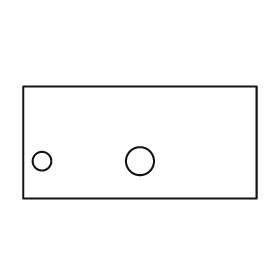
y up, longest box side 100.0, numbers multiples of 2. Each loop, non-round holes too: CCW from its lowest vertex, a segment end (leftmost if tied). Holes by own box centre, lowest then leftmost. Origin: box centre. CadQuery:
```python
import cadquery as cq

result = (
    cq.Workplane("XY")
    .moveTo(-50.0, -24.0)
    .lineTo(50.0, -24.0)
    .lineTo(50.0, 24.0)
    .lineTo(-50.0, 24.0)
    .close()
    .moveTo(-42.0, -8.0)
    .circle(4.0)
    .moveTo(0.0, -8.0)
    .circle(6.0)
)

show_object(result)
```